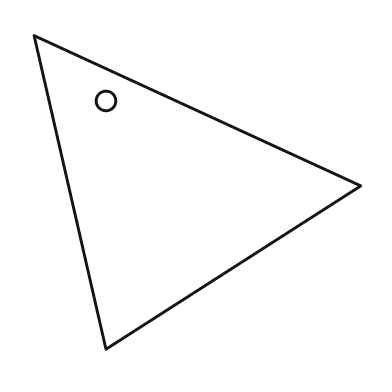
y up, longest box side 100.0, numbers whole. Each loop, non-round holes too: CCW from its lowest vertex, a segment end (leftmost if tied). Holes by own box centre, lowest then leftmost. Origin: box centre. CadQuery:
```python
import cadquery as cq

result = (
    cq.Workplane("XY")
    .moveTo(-28.0, -48.0)
    .lineTo(50.0, 2.0)
    .lineTo(-50.0, 48.0)
    .close()
    .moveTo(-28.0, 28.0)
    .circle(3.0)
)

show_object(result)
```